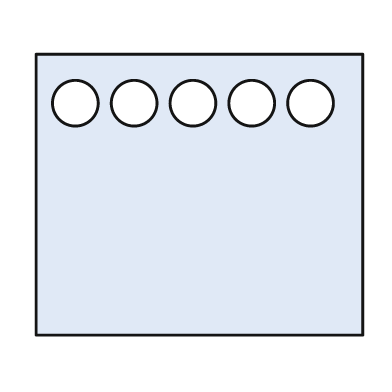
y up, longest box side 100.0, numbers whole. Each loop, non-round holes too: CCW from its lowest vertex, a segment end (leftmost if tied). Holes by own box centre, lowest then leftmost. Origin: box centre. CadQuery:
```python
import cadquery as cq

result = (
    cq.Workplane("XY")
    .moveTo(-50.0, -43.0)
    .lineTo(50.0, -43.0)
    .lineTo(50.0, 43.0)
    .lineTo(-50.0, 43.0)
    .close()
    .moveTo(-38.0, 28.0)
    .circle(7.0)
    .moveTo(-20.0, 28.0)
    .circle(7.0)
    .moveTo(-2.0, 28.0)
    .circle(7.0)
    .moveTo(16.0, 28.0)
    .circle(7.0)
    .moveTo(34.0, 28.0)
    .circle(7.0)
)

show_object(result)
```